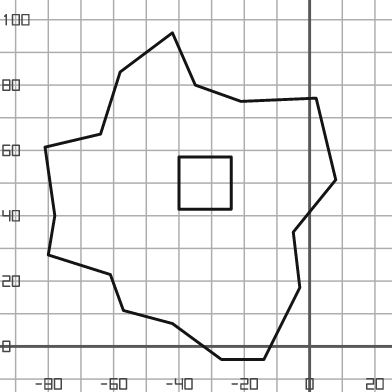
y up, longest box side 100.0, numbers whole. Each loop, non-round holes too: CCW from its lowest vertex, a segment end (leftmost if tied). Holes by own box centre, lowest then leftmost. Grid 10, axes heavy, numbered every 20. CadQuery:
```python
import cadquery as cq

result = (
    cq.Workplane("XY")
    .moveTo(-27.0, -4.0)
    .lineTo(-14.0, -4.0)
    .lineTo(-3.0, 18.0)
    .lineTo(-5.0, 35.0)
    .lineTo(8.0, 51.0)
    .lineTo(2.0, 76.0)
    .lineTo(-21.0, 75.0)
    .lineTo(-35.0, 80.0)
    .lineTo(-42.0, 96.0)
    .lineTo(-58.0, 84.0)
    .lineTo(-64.0, 65.0)
    .lineTo(-81.0, 61.0)
    .lineTo(-78.0, 40.0)
    .lineTo(-80.0, 28.0)
    .lineTo(-61.0, 22.0)
    .lineTo(-57.0, 11.0)
    .lineTo(-42.0, 7.0)
    .close()
    .moveTo(-40.0, 42.0)
    .lineTo(-24.0, 42.0)
    .lineTo(-24.0, 58.0)
    .lineTo(-40.0, 58.0)
    .close()
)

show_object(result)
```